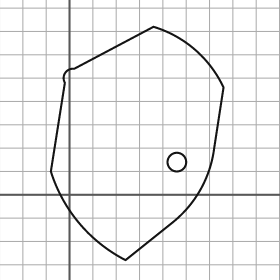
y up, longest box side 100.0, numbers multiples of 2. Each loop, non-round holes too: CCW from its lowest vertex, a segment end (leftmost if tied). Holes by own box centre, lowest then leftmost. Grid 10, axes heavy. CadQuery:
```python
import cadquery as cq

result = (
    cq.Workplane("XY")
    .moveTo(24.0, -28.0)
    .lineTo(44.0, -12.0)
    .threePointArc((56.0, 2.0), (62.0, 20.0))
    .lineTo(66.0, 46.0)
    .threePointArc((54.0, 62.0), (36.0, 72.0))
    .lineTo(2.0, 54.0)
    .threePointArc((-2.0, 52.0), (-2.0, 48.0))
    .lineTo(-8.0, 10.0)
    .threePointArc((4.0, -12.0), (24.0, -28.0))
    .close()
    .moveTo(46.0, 14.0)
    .circle(4.0)
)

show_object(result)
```